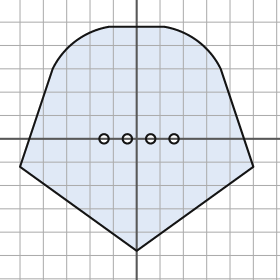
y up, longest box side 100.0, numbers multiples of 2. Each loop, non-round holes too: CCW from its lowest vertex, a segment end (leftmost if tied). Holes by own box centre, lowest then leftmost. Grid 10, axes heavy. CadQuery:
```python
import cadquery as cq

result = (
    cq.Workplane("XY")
    .moveTo(0.0, -48.0)
    .lineTo(50.0, -12.0)
    .lineTo(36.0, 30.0)
    .threePointArc((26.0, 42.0), (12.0, 48.0))
    .lineTo(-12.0, 48.0)
    .threePointArc((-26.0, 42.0), (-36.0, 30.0))
    .lineTo(-50.0, -12.0)
    .close()
    .moveTo(-14.0, 0.0)
    .circle(2.0)
    .moveTo(-4.0, 0.0)
    .circle(2.0)
    .moveTo(6.0, 0.0)
    .circle(2.0)
    .moveTo(16.0, 0.0)
    .circle(2.0)
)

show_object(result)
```